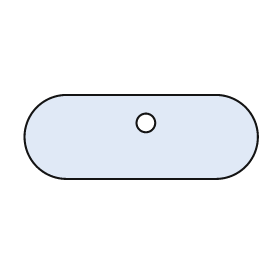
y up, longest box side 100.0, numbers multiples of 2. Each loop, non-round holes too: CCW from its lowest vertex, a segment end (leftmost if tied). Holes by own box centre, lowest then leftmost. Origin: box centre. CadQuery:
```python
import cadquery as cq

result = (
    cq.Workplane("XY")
    .moveTo(-32.0, -18.0)
    .lineTo(32.0, -18.0)
    .threePointArc((50.0, 0.0), (32.0, 18.0))
    .lineTo(-32.0, 18.0)
    .threePointArc((-50.0, 0.0), (-32.0, -18.0))
    .close()
    .moveTo(2.0, 6.0)
    .circle(4.0)
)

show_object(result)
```